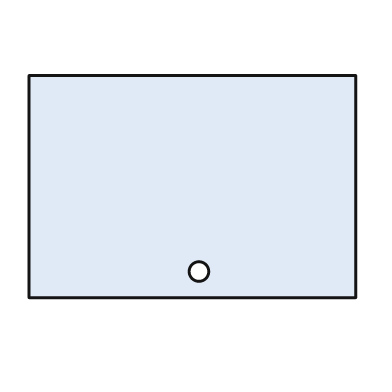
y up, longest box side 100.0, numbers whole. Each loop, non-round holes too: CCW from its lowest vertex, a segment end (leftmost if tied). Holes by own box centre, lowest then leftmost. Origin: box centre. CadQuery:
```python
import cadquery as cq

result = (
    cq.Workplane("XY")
    .moveTo(-50.0, -34.0)
    .lineTo(50.0, -34.0)
    .lineTo(50.0, 34.0)
    .lineTo(-50.0, 34.0)
    .close()
    .moveTo(2.0, -26.0)
    .circle(3.0)
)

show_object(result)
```